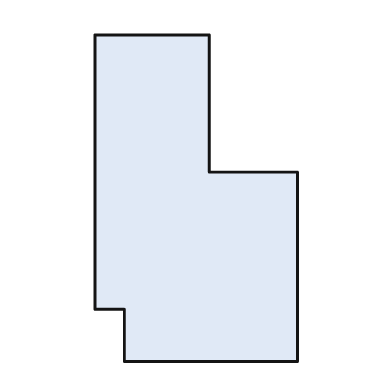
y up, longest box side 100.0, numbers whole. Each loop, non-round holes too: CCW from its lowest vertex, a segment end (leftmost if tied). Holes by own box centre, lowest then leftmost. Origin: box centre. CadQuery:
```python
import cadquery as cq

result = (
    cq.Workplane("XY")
    .moveTo(-22.0, -50.0)
    .lineTo(31.0, -50.0)
    .lineTo(31.0, 8.0)
    .lineTo(4.0, 8.0)
    .lineTo(4.0, 50.0)
    .lineTo(-31.0, 50.0)
    .lineTo(-31.0, -34.0)
    .lineTo(-22.0, -34.0)
    .close()
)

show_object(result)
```